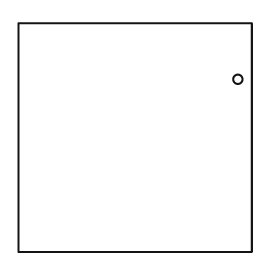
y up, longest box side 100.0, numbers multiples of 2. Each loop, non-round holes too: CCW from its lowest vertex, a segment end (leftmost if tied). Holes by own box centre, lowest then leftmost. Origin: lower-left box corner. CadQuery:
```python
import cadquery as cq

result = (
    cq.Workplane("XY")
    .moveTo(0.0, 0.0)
    .lineTo(100.0, 0.0)
    .lineTo(100.0, 98.0)
    .lineTo(0.0, 98.0)
    .close()
    .moveTo(94.0, 74.0)
    .circle(2.0)
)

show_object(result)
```